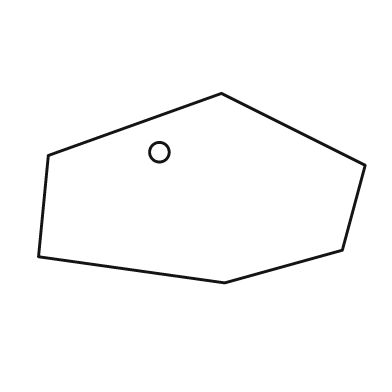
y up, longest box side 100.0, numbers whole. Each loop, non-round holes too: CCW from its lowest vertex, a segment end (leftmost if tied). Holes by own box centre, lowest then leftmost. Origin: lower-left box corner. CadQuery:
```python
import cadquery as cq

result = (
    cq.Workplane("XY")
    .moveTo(57.0, 0.0)
    .lineTo(93.0, 10.0)
    .lineTo(100.0, 36.0)
    .lineTo(56.0, 58.0)
    .lineTo(3.0, 39.0)
    .lineTo(0.0, 8.0)
    .close()
    .moveTo(37.0, 40.0)
    .circle(3.0)
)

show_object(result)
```